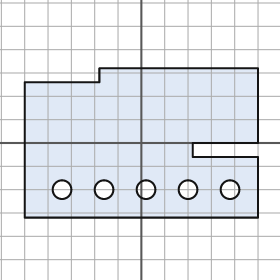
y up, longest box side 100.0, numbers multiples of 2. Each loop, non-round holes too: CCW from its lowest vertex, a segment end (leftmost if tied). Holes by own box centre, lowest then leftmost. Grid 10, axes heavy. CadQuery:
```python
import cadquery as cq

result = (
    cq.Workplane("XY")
    .moveTo(-50.0, -32.0)
    .lineTo(50.0, -32.0)
    .lineTo(50.0, -6.0)
    .lineTo(22.0, -6.0)
    .lineTo(22.0, 0.0)
    .lineTo(50.0, 0.0)
    .lineTo(50.0, 32.0)
    .lineTo(-18.0, 32.0)
    .lineTo(-18.0, 26.0)
    .lineTo(-50.0, 26.0)
    .close()
    .moveTo(-34.0, -20.0)
    .circle(4.0)
    .moveTo(-16.0, -20.0)
    .circle(4.0)
    .moveTo(2.0, -20.0)
    .circle(4.0)
    .moveTo(20.0, -20.0)
    .circle(4.0)
    .moveTo(38.0, -20.0)
    .circle(4.0)
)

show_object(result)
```